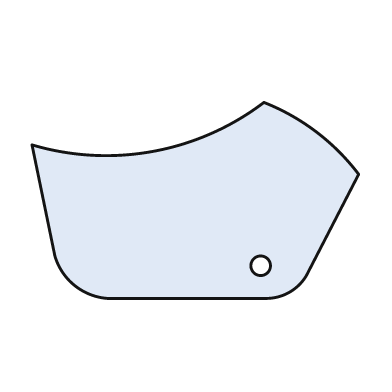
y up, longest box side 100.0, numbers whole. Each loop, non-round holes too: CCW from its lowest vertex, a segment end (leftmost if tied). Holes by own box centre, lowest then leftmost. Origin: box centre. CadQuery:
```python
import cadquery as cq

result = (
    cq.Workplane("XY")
    .moveTo(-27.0, -30.0)
    .lineTo(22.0, -30.0)
    .threePointArc((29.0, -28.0), (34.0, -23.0))
    .lineTo(50.0, 8.0)
    .threePointArc((37.0, 21.0), (21.0, 30.0))
    .threePointArc((-13.0, 15.0), (-50.0, 17.0))
    .lineTo(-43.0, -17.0)
    .threePointArc((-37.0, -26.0), (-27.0, -30.0))
    .close()
    .moveTo(20.0, -20.0)
    .circle(3.0)
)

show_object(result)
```